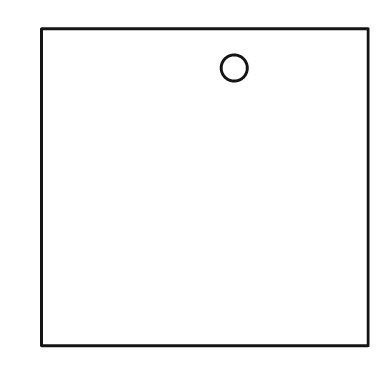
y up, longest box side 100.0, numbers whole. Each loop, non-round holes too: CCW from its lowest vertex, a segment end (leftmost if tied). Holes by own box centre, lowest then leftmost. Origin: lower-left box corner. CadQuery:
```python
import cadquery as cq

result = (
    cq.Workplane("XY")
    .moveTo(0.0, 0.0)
    .lineTo(100.0, 0.0)
    .lineTo(100.0, 97.0)
    .lineTo(0.0, 97.0)
    .close()
    .moveTo(59.0, 85.0)
    .circle(4.0)
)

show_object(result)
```